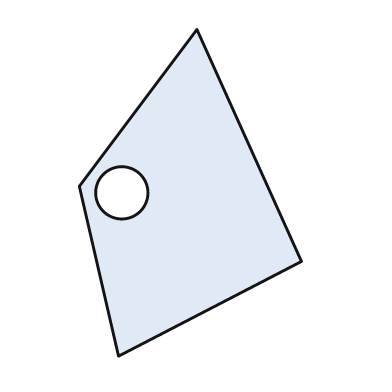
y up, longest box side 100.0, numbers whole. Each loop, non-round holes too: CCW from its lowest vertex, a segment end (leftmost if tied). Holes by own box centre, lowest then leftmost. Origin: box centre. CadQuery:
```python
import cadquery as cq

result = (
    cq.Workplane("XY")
    .moveTo(-22.0, -50.0)
    .lineTo(34.0, -21.0)
    .lineTo(2.0, 50.0)
    .lineTo(-34.0, 2.0)
    .close()
    .moveTo(-21.0, 0.0)
    .circle(8.0)
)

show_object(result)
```